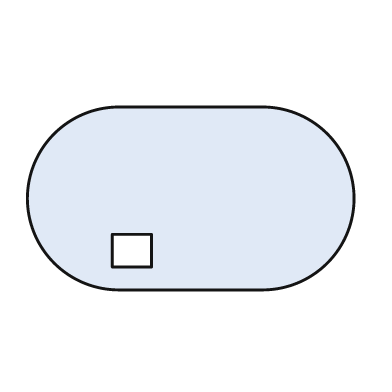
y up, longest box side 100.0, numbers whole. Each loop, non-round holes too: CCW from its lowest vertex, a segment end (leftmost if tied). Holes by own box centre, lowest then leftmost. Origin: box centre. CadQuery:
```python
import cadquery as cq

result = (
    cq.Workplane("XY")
    .moveTo(-22.0, -28.0)
    .lineTo(22.0, -28.0)
    .threePointArc((50.0, 0.0), (22.0, 28.0))
    .lineTo(-22.0, 28.0)
    .threePointArc((-50.0, 0.0), (-22.0, -28.0))
    .close()
    .moveTo(-24.0, -21.0)
    .lineTo(-12.0, -21.0)
    .lineTo(-12.0, -11.0)
    .lineTo(-24.0, -11.0)
    .close()
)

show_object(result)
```